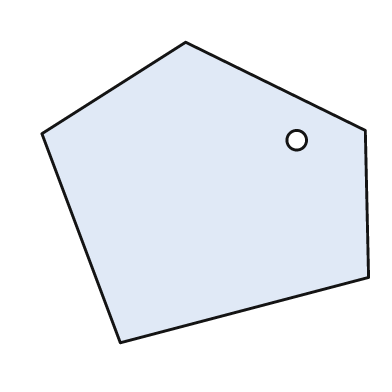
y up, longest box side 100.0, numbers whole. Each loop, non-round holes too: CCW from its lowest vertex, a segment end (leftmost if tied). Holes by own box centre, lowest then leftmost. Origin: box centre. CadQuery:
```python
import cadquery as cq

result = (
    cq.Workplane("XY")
    .moveTo(-26.0, -46.0)
    .lineTo(50.0, -26.0)
    .lineTo(49.0, 19.0)
    .lineTo(-6.0, 46.0)
    .lineTo(-50.0, 18.0)
    .close()
    .moveTo(28.0, 16.0)
    .circle(3.0)
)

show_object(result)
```